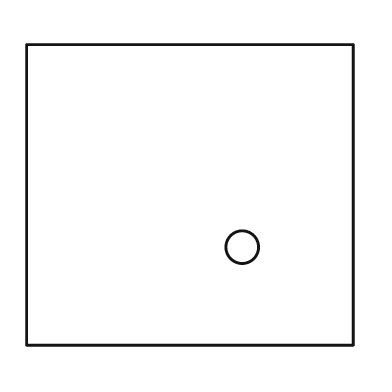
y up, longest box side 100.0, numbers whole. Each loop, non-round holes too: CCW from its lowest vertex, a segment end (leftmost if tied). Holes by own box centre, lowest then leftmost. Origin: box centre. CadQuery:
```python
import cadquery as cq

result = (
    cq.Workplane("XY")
    .moveTo(-50.0, -46.0)
    .lineTo(50.0, -46.0)
    .lineTo(50.0, 46.0)
    .lineTo(-50.0, 46.0)
    .close()
    .moveTo(16.0, -16.0)
    .circle(5.0)
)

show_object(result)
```